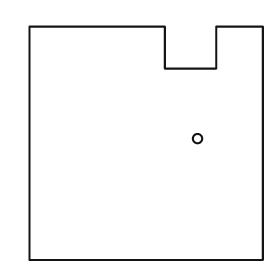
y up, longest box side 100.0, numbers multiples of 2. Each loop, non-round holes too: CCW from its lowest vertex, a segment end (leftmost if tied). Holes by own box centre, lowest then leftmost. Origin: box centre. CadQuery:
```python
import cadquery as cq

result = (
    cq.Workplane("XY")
    .moveTo(-50.0, -50.0)
    .lineTo(50.0, -50.0)
    .lineTo(50.0, 50.0)
    .lineTo(30.0, 50.0)
    .lineTo(30.0, 32.0)
    .lineTo(8.0, 32.0)
    .lineTo(8.0, 50.0)
    .lineTo(-50.0, 50.0)
    .close()
    .moveTo(22.0, 2.0)
    .circle(2.0)
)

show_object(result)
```